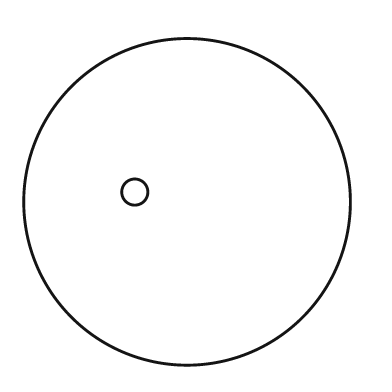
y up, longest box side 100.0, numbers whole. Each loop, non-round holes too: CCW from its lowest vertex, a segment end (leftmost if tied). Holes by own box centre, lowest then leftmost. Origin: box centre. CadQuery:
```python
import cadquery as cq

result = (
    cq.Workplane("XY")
    .moveTo(0.0, 0.0)
    .circle(50.0)
    .moveTo(-16.0, 3.0)
    .circle(4.0)
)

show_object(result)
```